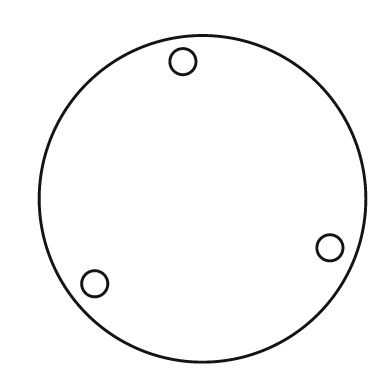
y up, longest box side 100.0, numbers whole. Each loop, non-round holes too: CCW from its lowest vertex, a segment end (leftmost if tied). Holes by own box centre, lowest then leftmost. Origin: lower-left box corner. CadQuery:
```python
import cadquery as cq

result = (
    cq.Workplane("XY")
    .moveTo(50.0, 50.0)
    .circle(50.0)
    .moveTo(17.0, 24.0)
    .circle(4.0)
    .moveTo(89.0, 35.0)
    .circle(4.0)
    .moveTo(44.0, 92.0)
    .circle(4.0)
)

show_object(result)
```